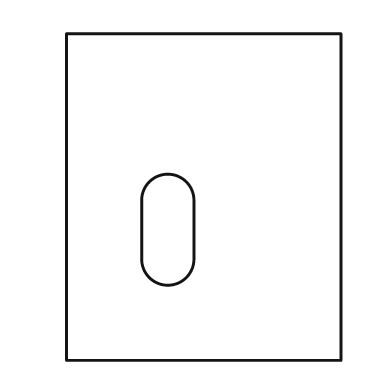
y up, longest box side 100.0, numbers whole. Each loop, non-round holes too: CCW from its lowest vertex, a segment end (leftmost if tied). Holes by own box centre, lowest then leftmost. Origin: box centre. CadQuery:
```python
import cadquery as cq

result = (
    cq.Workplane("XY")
    .moveTo(-42.0, -50.0)
    .lineTo(42.0, -50.0)
    .lineTo(42.0, 50.0)
    .lineTo(-42.0, 50.0)
    .close()
    .moveTo(-19.0, -19.0)
    .threePointArc((-11.0, -27.0), (-3.0, -19.0))
    .lineTo(-3.0, -1.0)
    .threePointArc((-11.0, 7.0), (-19.0, -1.0))
    .close()
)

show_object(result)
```